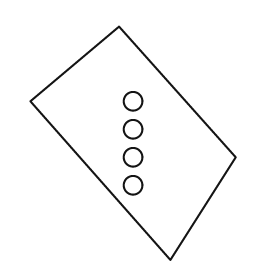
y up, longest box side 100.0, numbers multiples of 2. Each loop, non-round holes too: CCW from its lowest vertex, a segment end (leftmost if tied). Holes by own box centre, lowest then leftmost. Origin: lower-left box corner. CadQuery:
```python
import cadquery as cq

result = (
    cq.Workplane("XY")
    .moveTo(60.0, 0.0)
    .lineTo(88.0, 44.0)
    .lineTo(38.0, 100.0)
    .lineTo(0.0, 68.0)
    .close()
    .moveTo(44.0, 32.0)
    .circle(4.0)
    .moveTo(44.0, 44.0)
    .circle(4.0)
    .moveTo(44.0, 56.0)
    .circle(4.0)
    .moveTo(44.0, 68.0)
    .circle(4.0)
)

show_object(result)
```